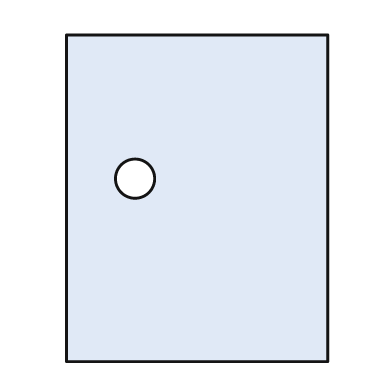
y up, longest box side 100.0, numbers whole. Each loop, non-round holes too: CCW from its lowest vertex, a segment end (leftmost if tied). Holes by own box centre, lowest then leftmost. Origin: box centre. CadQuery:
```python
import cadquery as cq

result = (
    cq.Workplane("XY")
    .moveTo(-40.0, -50.0)
    .lineTo(40.0, -50.0)
    .lineTo(40.0, 50.0)
    .lineTo(-40.0, 50.0)
    .close()
    .moveTo(-19.0, 6.0)
    .circle(6.0)
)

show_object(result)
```